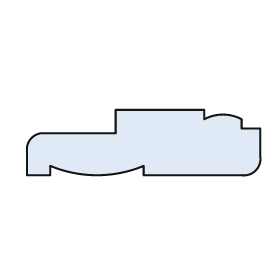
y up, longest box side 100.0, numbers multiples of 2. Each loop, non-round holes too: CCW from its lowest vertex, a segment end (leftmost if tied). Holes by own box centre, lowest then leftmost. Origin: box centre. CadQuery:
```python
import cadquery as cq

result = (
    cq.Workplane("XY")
    .moveTo(-50.0, -14.0)
    .lineTo(-40.0, -14.0)
    .lineTo(-40.0, -10.0)
    .threePointArc((-20.0, -14.0), (0.0, -10.0))
    .lineTo(0.0, -14.0)
    .lineTo(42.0, -14.0)
    .threePointArc((48.0, -12.0), (50.0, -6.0))
    .lineTo(50.0, 6.0)
    .lineTo(42.0, 6.0)
    .lineTo(42.0, 10.0)
    .threePointArc((34.0, 12.0), (26.0, 10.0))
    .lineTo(26.0, 14.0)
    .lineTo(-12.0, 14.0)
    .lineTo(-12.0, 4.0)
    .lineTo(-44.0, 4.0)
    .threePointArc((-48.0, 2.0), (-50.0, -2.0))
    .close()
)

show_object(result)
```